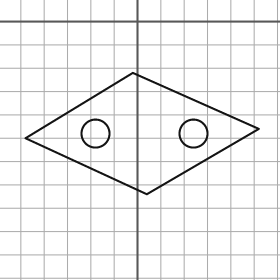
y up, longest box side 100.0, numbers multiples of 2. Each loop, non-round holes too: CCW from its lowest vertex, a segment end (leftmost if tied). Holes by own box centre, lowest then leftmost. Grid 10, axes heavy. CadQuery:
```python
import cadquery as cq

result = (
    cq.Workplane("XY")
    .moveTo(4.0, -74.0)
    .lineTo(52.0, -46.0)
    .lineTo(-2.0, -22.0)
    .lineTo(-48.0, -50.0)
    .close()
    .moveTo(-18.0, -48.0)
    .circle(6.0)
    .moveTo(24.0, -48.0)
    .circle(6.0)
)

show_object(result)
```